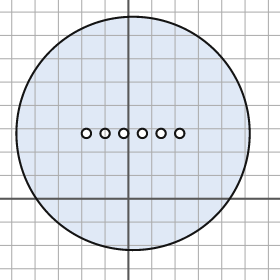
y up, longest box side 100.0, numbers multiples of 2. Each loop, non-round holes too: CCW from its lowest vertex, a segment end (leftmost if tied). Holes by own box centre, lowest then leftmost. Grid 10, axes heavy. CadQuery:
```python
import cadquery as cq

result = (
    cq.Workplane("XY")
    .moveTo(2.0, 28.0)
    .circle(50.0)
    .moveTo(-18.0, 28.0)
    .circle(2.0)
    .moveTo(-10.0, 28.0)
    .circle(2.0)
    .moveTo(-2.0, 28.0)
    .circle(2.0)
    .moveTo(6.0, 28.0)
    .circle(2.0)
    .moveTo(14.0, 28.0)
    .circle(2.0)
    .moveTo(22.0, 28.0)
    .circle(2.0)
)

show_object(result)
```